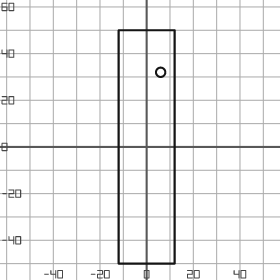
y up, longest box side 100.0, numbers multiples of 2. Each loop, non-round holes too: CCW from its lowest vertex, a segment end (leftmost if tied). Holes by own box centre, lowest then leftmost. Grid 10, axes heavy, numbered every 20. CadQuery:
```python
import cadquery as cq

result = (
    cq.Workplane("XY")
    .moveTo(-12.0, -50.0)
    .lineTo(12.0, -50.0)
    .lineTo(12.0, 50.0)
    .lineTo(-12.0, 50.0)
    .close()
    .moveTo(6.0, 32.0)
    .circle(2.0)
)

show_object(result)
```